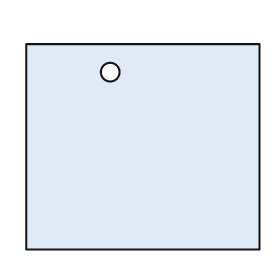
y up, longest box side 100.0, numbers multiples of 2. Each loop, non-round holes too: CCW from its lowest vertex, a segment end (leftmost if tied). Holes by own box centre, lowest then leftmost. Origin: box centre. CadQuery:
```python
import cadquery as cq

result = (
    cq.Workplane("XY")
    .moveTo(-50.0, -44.0)
    .lineTo(50.0, -44.0)
    .lineTo(50.0, 44.0)
    .lineTo(-50.0, 44.0)
    .close()
    .moveTo(-14.0, 32.0)
    .circle(4.0)
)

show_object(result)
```